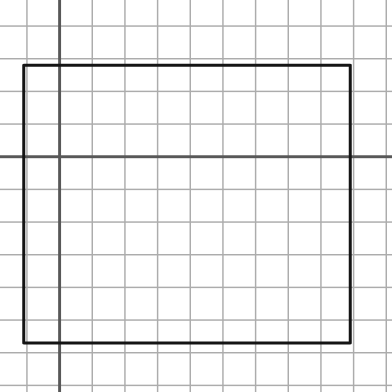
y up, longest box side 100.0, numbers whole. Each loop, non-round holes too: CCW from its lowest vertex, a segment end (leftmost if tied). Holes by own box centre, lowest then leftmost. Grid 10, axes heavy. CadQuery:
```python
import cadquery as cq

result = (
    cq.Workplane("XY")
    .moveTo(-11.0, -57.0)
    .lineTo(89.0, -57.0)
    .lineTo(89.0, 28.0)
    .lineTo(-11.0, 28.0)
    .close()
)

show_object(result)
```